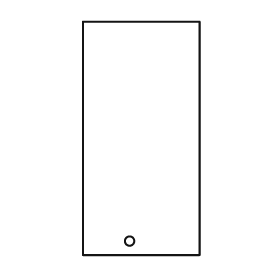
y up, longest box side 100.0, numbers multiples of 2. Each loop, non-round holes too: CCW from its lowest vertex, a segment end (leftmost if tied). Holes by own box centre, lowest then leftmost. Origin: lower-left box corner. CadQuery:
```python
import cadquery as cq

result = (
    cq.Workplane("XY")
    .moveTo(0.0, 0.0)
    .lineTo(50.0, 0.0)
    .lineTo(50.0, 100.0)
    .lineTo(0.0, 100.0)
    .close()
    .moveTo(20.0, 6.0)
    .circle(2.0)
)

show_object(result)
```